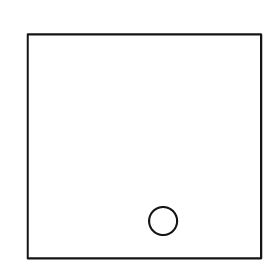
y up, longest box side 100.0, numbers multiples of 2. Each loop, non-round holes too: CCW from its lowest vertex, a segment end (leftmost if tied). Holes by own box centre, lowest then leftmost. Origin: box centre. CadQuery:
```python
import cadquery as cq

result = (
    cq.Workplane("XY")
    .moveTo(-50.0, -48.0)
    .lineTo(50.0, -48.0)
    .lineTo(50.0, 48.0)
    .lineTo(-50.0, 48.0)
    .close()
    .moveTo(8.0, -32.0)
    .circle(6.0)
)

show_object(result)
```